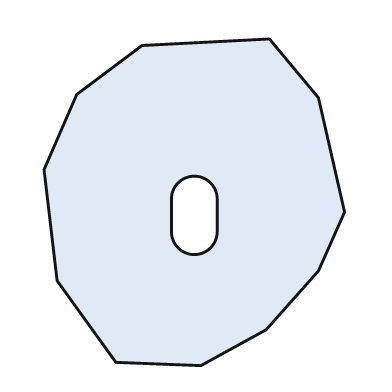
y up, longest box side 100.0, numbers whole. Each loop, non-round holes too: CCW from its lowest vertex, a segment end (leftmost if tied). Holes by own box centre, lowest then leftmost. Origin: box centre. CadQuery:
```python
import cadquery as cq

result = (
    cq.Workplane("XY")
    .moveTo(2.0, -50.0)
    .lineTo(22.0, -39.0)
    .lineTo(38.0, -21.0)
    .lineTo(46.0, -3.0)
    .lineTo(38.0, 32.0)
    .lineTo(23.0, 50.0)
    .lineTo(-16.0, 48.0)
    .lineTo(-36.0, 33.0)
    .lineTo(-46.0, 10.0)
    .lineTo(-42.0, -24.0)
    .lineTo(-24.0, -49.0)
    .close()
    .moveTo(-7.0, -9.0)
    .threePointArc((0.0, -16.0), (7.0, -9.0))
    .lineTo(7.0, 1.0)
    .threePointArc((0.0, 8.0), (-7.0, 1.0))
    .close()
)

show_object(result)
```